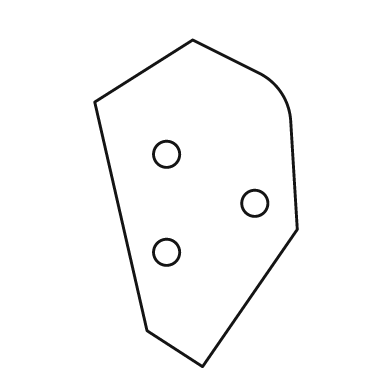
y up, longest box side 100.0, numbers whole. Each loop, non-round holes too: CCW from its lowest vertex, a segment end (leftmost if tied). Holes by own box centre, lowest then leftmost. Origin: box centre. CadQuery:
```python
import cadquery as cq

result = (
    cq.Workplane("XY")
    .moveTo(2.0, -50.0)
    .lineTo(31.0, -8.0)
    .lineTo(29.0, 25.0)
    .threePointArc((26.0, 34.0), (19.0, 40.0))
    .lineTo(-1.0, 50.0)
    .lineTo(-31.0, 31.0)
    .lineTo(-15.0, -39.0)
    .close()
    .moveTo(-9.0, -15.0)
    .circle(4.0)
    .moveTo(18.0, 0.0)
    .circle(4.0)
    .moveTo(-9.0, 15.0)
    .circle(4.0)
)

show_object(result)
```